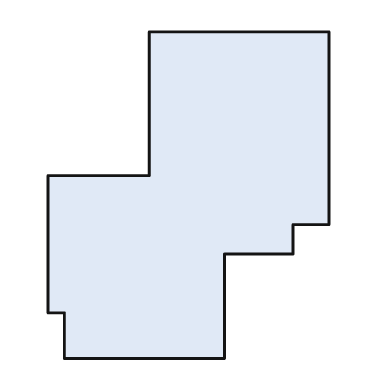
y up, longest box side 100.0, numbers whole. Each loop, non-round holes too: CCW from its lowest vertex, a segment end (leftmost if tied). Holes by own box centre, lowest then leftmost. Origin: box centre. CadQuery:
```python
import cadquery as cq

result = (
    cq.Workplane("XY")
    .moveTo(-38.0, -50.0)
    .lineTo(11.0, -50.0)
    .lineTo(11.0, -18.0)
    .lineTo(32.0, -18.0)
    .lineTo(32.0, -9.0)
    .lineTo(43.0, -9.0)
    .lineTo(43.0, 50.0)
    .lineTo(-12.0, 50.0)
    .lineTo(-12.0, 6.0)
    .lineTo(-43.0, 6.0)
    .lineTo(-43.0, -36.0)
    .lineTo(-38.0, -36.0)
    .close()
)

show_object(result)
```